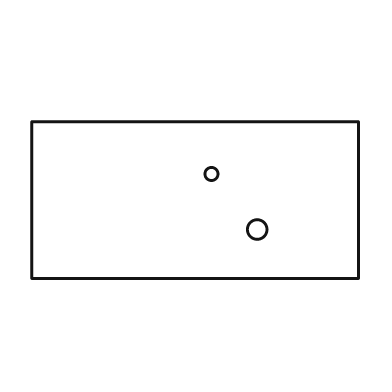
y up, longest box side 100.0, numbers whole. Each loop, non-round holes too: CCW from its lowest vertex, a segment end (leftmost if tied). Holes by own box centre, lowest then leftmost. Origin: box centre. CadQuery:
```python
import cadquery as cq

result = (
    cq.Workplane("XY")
    .moveTo(-50.0, -24.0)
    .lineTo(50.0, -24.0)
    .lineTo(50.0, 24.0)
    .lineTo(-50.0, 24.0)
    .close()
    .moveTo(19.0, -9.0)
    .circle(3.0)
    .moveTo(5.0, 8.0)
    .circle(2.0)
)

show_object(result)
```